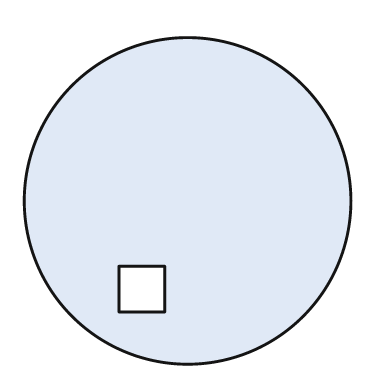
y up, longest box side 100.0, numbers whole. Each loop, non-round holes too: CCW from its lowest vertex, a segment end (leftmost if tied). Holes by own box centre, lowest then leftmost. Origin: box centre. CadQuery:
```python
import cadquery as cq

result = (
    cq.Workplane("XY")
    .moveTo(0.0, 0.0)
    .circle(50.0)
    .moveTo(-21.0, -34.0)
    .lineTo(-7.0, -34.0)
    .lineTo(-7.0, -20.0)
    .lineTo(-21.0, -20.0)
    .close()
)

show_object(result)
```